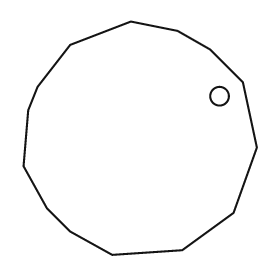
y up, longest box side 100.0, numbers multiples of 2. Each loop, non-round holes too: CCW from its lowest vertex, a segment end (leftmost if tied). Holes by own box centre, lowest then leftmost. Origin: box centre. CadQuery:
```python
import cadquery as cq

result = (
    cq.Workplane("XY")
    .moveTo(-12.0, -50.0)
    .lineTo(18.0, -48.0)
    .lineTo(40.0, -32.0)
    .lineTo(50.0, -4.0)
    .lineTo(44.0, 24.0)
    .lineTo(30.0, 38.0)
    .lineTo(16.0, 46.0)
    .lineTo(-4.0, 50.0)
    .lineTo(-30.0, 40.0)
    .lineTo(-44.0, 22.0)
    .lineTo(-48.0, 12.0)
    .lineTo(-50.0, -12.0)
    .lineTo(-40.0, -30.0)
    .lineTo(-30.0, -40.0)
    .close()
    .moveTo(34.0, 18.0)
    .circle(4.0)
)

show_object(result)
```